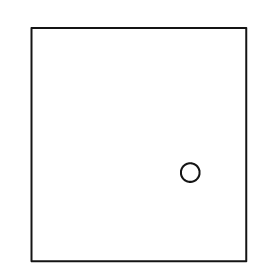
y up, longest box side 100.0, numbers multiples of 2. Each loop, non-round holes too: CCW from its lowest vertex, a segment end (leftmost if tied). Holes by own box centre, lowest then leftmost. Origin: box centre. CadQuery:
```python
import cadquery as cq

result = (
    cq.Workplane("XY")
    .moveTo(-46.0, -50.0)
    .lineTo(46.0, -50.0)
    .lineTo(46.0, 50.0)
    .lineTo(-46.0, 50.0)
    .close()
    .moveTo(22.0, -12.0)
    .circle(4.0)
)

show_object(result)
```